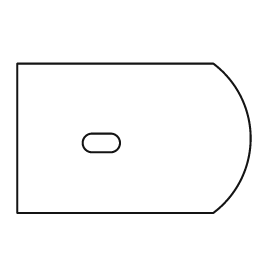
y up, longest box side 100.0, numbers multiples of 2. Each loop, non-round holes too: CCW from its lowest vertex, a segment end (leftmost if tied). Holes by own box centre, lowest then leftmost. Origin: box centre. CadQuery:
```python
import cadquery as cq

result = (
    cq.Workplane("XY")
    .moveTo(-50.0, -32.0)
    .lineTo(34.0, -32.0)
    .threePointArc((50.0, 0.0), (34.0, 32.0))
    .lineTo(-50.0, 32.0)
    .close()
    .moveTo(-18.0, -6.0)
    .lineTo(-10.0, -6.0)
    .threePointArc((-6.0, -2.0), (-10.0, 2.0))
    .lineTo(-18.0, 2.0)
    .threePointArc((-22.0, -2.0), (-18.0, -6.0))
    .close()
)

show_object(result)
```